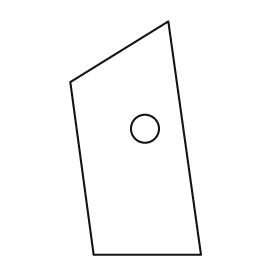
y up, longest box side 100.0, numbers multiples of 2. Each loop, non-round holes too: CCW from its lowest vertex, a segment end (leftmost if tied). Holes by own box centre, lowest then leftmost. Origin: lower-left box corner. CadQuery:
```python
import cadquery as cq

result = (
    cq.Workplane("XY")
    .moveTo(10.0, 0.0)
    .lineTo(56.0, 0.0)
    .lineTo(42.0, 100.0)
    .lineTo(0.0, 74.0)
    .close()
    .moveTo(32.0, 54.0)
    .circle(6.0)
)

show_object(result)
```